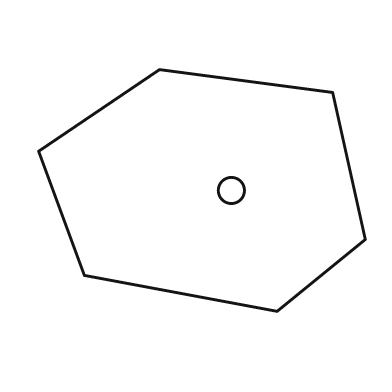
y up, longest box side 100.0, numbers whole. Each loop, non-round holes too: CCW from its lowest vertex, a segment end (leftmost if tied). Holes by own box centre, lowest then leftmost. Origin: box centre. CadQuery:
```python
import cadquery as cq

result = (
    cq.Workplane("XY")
    .moveTo(23.0, -37.0)
    .lineTo(50.0, -15.0)
    .lineTo(40.0, 30.0)
    .lineTo(-13.0, 37.0)
    .lineTo(-50.0, 12.0)
    .lineTo(-36.0, -26.0)
    .close()
    .moveTo(9.0, 0.0)
    .circle(4.0)
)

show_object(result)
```